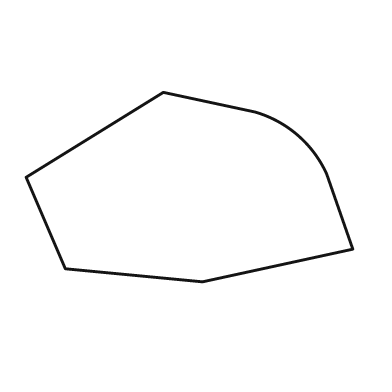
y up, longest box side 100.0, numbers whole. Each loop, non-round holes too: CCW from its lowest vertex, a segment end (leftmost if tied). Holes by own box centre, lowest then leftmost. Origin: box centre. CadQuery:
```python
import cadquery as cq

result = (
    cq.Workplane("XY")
    .moveTo(4.0, -29.0)
    .lineTo(50.0, -19.0)
    .lineTo(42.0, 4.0)
    .threePointArc((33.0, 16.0), (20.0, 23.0))
    .lineTo(-8.0, 29.0)
    .lineTo(-50.0, 3.0)
    .lineTo(-38.0, -25.0)
    .close()
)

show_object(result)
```